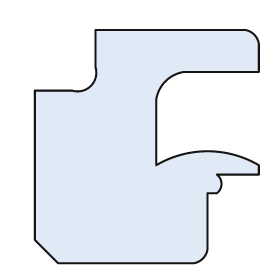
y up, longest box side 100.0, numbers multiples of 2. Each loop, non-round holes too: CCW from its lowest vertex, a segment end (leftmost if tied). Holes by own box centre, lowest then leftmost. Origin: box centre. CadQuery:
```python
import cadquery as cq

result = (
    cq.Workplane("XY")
    .moveTo(-38.0, -50.0)
    .lineTo(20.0, -50.0)
    .threePointArc((24.0, -48.0), (26.0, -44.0))
    .lineTo(26.0, -20.0)
    .lineTo(30.0, -20.0)
    .threePointArc((32.0, -16.0), (30.0, -12.0))
    .lineTo(48.0, -12.0)
    .lineTo(48.0, -8.0)
    .threePointArc((26.0, -2.0), (4.0, -8.0))
    .lineTo(4.0, 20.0)
    .threePointArc((8.0, 28.0), (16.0, 32.0))
    .lineTo(48.0, 32.0)
    .lineTo(48.0, 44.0)
    .threePointArc((46.0, 48.0), (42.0, 50.0))
    .lineTo(-22.0, 50.0)
    .lineTo(-22.0, 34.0)
    .threePointArc((-24.0, 26.0), (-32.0, 24.0))
    .lineTo(-48.0, 24.0)
    .lineTo(-48.0, -40.0)
    .close()
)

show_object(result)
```